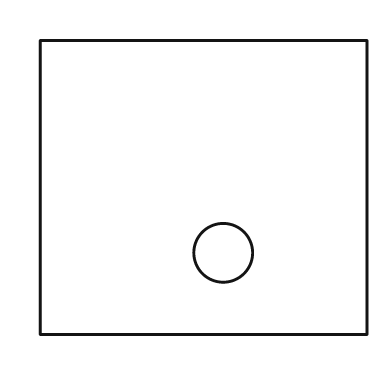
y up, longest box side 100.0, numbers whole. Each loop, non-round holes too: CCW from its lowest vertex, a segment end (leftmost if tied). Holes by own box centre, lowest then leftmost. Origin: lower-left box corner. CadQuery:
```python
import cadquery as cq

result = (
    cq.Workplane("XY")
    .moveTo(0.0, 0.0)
    .lineTo(100.0, 0.0)
    .lineTo(100.0, 90.0)
    .lineTo(0.0, 90.0)
    .close()
    .moveTo(56.0, 25.0)
    .circle(9.0)
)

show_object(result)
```